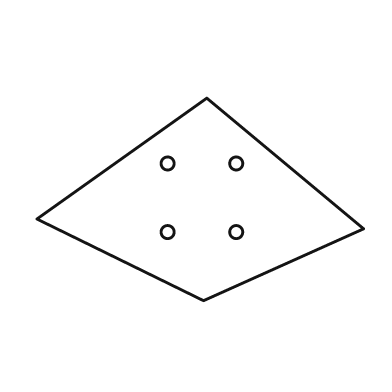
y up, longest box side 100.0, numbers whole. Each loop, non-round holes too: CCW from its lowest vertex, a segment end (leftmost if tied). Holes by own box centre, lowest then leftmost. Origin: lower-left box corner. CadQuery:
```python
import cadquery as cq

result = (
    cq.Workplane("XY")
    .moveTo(51.0, 0.0)
    .lineTo(100.0, 22.0)
    .lineTo(52.0, 62.0)
    .lineTo(0.0, 25.0)
    .close()
    .moveTo(40.0, 21.0)
    .circle(2.0)
    .moveTo(61.0, 21.0)
    .circle(2.0)
    .moveTo(40.0, 42.0)
    .circle(2.0)
    .moveTo(61.0, 42.0)
    .circle(2.0)
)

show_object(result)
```